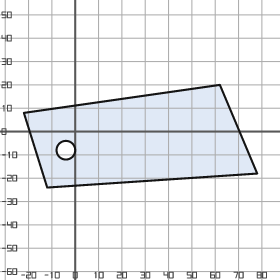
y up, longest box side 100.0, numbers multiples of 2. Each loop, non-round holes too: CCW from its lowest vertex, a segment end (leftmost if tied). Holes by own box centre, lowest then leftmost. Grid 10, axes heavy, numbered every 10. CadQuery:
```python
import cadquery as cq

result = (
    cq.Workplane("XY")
    .moveTo(-12.0, -24.0)
    .lineTo(78.0, -18.0)
    .lineTo(62.0, 20.0)
    .lineTo(-22.0, 8.0)
    .close()
    .moveTo(-4.0, -8.0)
    .circle(4.0)
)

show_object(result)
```